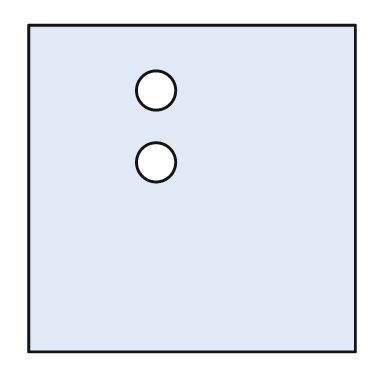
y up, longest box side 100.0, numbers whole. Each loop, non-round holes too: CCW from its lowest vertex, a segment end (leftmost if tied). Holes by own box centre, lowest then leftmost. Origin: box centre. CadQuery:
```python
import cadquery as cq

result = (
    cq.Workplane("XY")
    .moveTo(-50.0, -50.0)
    .lineTo(50.0, -50.0)
    .lineTo(50.0, 50.0)
    .lineTo(-50.0, 50.0)
    .close()
    .moveTo(-11.0, 8.0)
    .circle(6.0)
    .moveTo(-11.0, 30.0)
    .circle(6.0)
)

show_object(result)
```